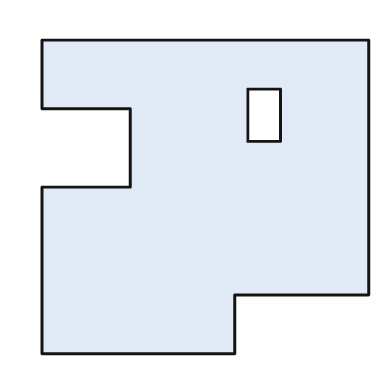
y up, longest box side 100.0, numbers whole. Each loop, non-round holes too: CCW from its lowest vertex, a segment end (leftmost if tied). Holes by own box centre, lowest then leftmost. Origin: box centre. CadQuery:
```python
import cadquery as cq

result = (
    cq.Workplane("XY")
    .moveTo(-50.0, -48.0)
    .lineTo(9.0, -48.0)
    .lineTo(9.0, -30.0)
    .lineTo(50.0, -30.0)
    .lineTo(50.0, 48.0)
    .lineTo(-50.0, 48.0)
    .lineTo(-50.0, 27.0)
    .lineTo(-23.0, 27.0)
    .lineTo(-23.0, 3.0)
    .lineTo(-50.0, 3.0)
    .close()
    .moveTo(13.0, 17.0)
    .lineTo(23.0, 17.0)
    .lineTo(23.0, 33.0)
    .lineTo(13.0, 33.0)
    .close()
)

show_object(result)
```